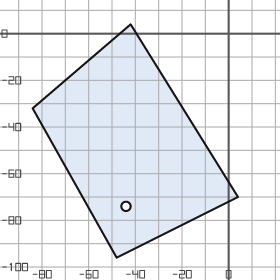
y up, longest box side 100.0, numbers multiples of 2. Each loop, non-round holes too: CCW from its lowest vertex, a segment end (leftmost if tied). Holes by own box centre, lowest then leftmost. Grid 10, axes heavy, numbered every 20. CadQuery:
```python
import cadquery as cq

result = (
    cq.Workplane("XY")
    .moveTo(-48.0, -96.0)
    .lineTo(4.0, -70.0)
    .lineTo(-42.0, 4.0)
    .lineTo(-84.0, -32.0)
    .close()
    .moveTo(-44.0, -74.0)
    .circle(2.0)
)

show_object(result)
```